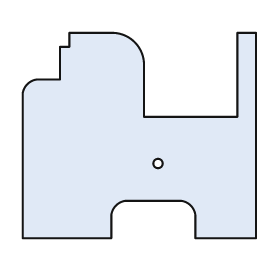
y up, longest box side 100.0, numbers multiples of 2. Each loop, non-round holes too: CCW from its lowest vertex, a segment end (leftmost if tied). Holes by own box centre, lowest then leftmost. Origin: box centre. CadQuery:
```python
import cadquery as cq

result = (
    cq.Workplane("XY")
    .moveTo(-50.0, -44.0)
    .lineTo(-12.0, -44.0)
    .lineTo(-12.0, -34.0)
    .threePointArc((-10.0, -30.0), (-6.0, -28.0))
    .lineTo(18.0, -28.0)
    .threePointArc((22.0, -30.0), (24.0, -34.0))
    .lineTo(24.0, -44.0)
    .lineTo(50.0, -44.0)
    .lineTo(50.0, 44.0)
    .lineTo(42.0, 44.0)
    .lineTo(42.0, 8.0)
    .lineTo(2.0, 8.0)
    .lineTo(2.0, 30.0)
    .threePointArc((-2.0, 40.0), (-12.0, 44.0))
    .lineTo(-30.0, 44.0)
    .lineTo(-30.0, 38.0)
    .lineTo(-34.0, 38.0)
    .lineTo(-34.0, 24.0)
    .lineTo(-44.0, 24.0)
    .threePointArc((-48.0, 22.0), (-50.0, 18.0))
    .close()
    .moveTo(8.0, -12.0)
    .circle(2.0)
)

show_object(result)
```